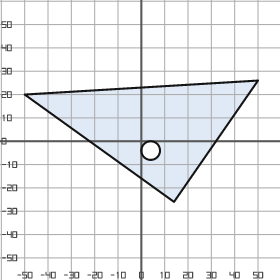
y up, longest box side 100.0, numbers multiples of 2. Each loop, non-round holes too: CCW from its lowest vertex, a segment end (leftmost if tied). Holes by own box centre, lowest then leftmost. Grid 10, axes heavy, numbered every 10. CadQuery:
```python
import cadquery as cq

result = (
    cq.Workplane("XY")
    .moveTo(14.0, -26.0)
    .lineTo(50.0, 26.0)
    .lineTo(-50.0, 20.0)
    .close()
    .moveTo(4.0, -4.0)
    .circle(4.0)
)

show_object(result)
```